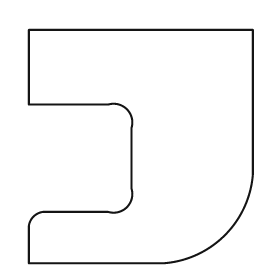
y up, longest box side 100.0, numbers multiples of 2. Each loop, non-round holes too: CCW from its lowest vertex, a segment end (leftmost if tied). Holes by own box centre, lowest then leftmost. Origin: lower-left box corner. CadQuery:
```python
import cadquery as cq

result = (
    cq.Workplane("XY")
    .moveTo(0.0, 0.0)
    .lineTo(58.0, 0.0)
    .threePointArc((84.0, 12.0), (96.0, 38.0))
    .lineTo(96.0, 100.0)
    .lineTo(0.0, 100.0)
    .lineTo(0.0, 68.0)
    .lineTo(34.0, 68.0)
    .threePointArc((42.0, 66.0), (44.0, 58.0))
    .lineTo(44.0, 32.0)
    .threePointArc((42.0, 24.0), (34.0, 22.0))
    .lineTo(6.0, 22.0)
    .threePointArc((2.0, 20.0), (0.0, 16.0))
    .close()
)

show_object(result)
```